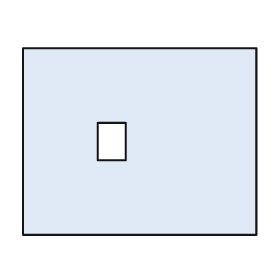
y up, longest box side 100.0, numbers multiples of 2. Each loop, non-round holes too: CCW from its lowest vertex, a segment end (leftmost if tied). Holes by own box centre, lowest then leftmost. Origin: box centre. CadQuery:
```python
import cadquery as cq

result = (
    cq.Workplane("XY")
    .moveTo(-50.0, -40.0)
    .lineTo(50.0, -40.0)
    .lineTo(50.0, 40.0)
    .lineTo(-50.0, 40.0)
    .close()
    .moveTo(-18.0, -8.0)
    .lineTo(-6.0, -8.0)
    .lineTo(-6.0, 8.0)
    .lineTo(-18.0, 8.0)
    .close()
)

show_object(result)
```